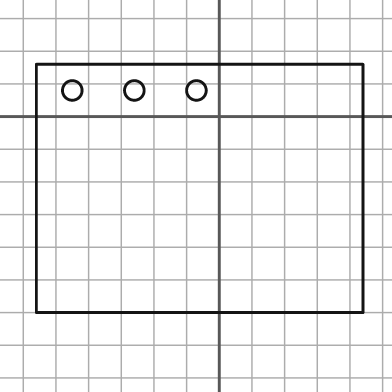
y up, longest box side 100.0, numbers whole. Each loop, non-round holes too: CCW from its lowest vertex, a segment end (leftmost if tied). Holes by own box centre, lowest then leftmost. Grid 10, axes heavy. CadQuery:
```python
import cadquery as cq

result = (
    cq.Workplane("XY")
    .moveTo(-56.0, -60.0)
    .lineTo(44.0, -60.0)
    .lineTo(44.0, 16.0)
    .lineTo(-56.0, 16.0)
    .close()
    .moveTo(-45.0, 8.0)
    .circle(3.0)
    .moveTo(-26.0, 8.0)
    .circle(3.0)
    .moveTo(-7.0, 8.0)
    .circle(3.0)
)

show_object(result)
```